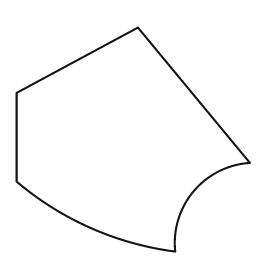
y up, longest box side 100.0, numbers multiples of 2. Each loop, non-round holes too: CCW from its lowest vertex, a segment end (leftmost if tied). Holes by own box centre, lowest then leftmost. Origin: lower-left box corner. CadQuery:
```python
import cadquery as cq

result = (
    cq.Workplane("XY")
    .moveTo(68.0, 0.0)
    .threePointArc((76.0, 26.0), (100.0, 38.0))
    .lineTo(52.0, 96.0)
    .lineTo(0.0, 68.0)
    .lineTo(0.0, 30.0)
    .threePointArc((32.0, 10.0), (68.0, 0.0))
    .close()
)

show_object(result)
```